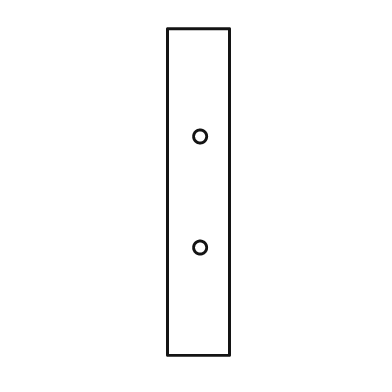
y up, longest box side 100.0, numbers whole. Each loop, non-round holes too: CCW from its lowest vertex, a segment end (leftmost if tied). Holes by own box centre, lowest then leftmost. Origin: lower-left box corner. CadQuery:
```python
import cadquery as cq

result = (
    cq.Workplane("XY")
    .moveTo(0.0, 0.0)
    .lineTo(19.0, 0.0)
    .lineTo(19.0, 100.0)
    .lineTo(0.0, 100.0)
    .close()
    .moveTo(10.0, 33.0)
    .circle(2.0)
    .moveTo(10.0, 67.0)
    .circle(2.0)
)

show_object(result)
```